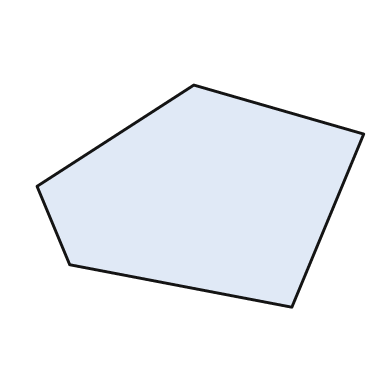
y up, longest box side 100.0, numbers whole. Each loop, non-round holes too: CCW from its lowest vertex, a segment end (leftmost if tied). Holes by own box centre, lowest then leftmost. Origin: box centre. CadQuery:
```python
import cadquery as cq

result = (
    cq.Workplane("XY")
    .moveTo(28.0, -34.0)
    .lineTo(50.0, 19.0)
    .lineTo(-2.0, 34.0)
    .lineTo(-50.0, 3.0)
    .lineTo(-40.0, -21.0)
    .close()
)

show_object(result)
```